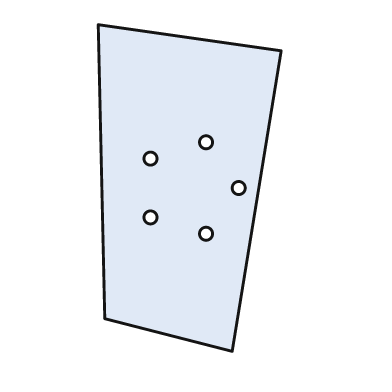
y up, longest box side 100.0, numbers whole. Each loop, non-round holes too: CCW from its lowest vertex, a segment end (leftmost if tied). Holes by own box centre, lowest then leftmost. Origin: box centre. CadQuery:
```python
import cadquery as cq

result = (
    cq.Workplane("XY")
    .moveTo(13.0, -50.0)
    .lineTo(28.0, 42.0)
    .lineTo(-28.0, 50.0)
    .lineTo(-26.0, -40.0)
    .close()
    .moveTo(5.0, -14.0)
    .circle(2.0)
    .moveTo(-12.0, -9.0)
    .circle(2.0)
    .moveTo(15.0, 0.0)
    .circle(2.0)
    .moveTo(-12.0, 9.0)
    .circle(2.0)
    .moveTo(5.0, 14.0)
    .circle(2.0)
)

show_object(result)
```